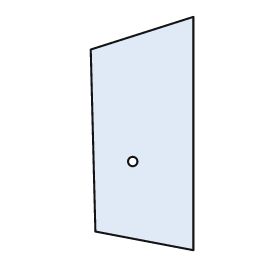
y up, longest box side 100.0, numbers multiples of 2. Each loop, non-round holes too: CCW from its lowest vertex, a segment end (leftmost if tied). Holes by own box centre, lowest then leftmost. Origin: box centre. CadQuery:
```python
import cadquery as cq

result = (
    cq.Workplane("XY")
    .moveTo(22.0, -50.0)
    .lineTo(22.0, 50.0)
    .lineTo(-22.0, 36.0)
    .lineTo(-20.0, -42.0)
    .close()
    .moveTo(-4.0, -12.0)
    .circle(2.0)
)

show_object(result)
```